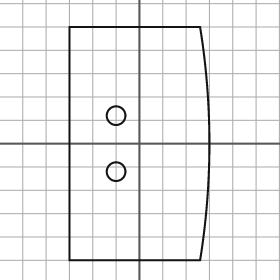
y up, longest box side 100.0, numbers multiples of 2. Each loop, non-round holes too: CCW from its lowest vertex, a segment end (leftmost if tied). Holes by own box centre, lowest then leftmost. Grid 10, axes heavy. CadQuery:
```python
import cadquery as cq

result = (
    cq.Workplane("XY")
    .moveTo(-30.0, -50.0)
    .lineTo(26.0, -50.0)
    .threePointArc((30.0, 0.0), (26.0, 50.0))
    .lineTo(-30.0, 50.0)
    .close()
    .moveTo(-10.0, -12.0)
    .circle(4.0)
    .moveTo(-10.0, 12.0)
    .circle(4.0)
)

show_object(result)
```